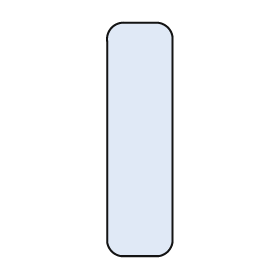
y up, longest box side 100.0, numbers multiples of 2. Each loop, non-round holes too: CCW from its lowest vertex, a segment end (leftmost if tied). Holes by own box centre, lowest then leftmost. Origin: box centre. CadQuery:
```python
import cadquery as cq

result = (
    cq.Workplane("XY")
    .moveTo(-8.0, -50.0)
    .lineTo(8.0, -50.0)
    .threePointArc((12.0, -48.0), (14.0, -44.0))
    .lineTo(14.0, 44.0)
    .threePointArc((12.0, 48.0), (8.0, 50.0))
    .lineTo(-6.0, 50.0)
    .threePointArc((-12.0, 48.0), (-14.0, 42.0))
    .lineTo(-14.0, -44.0)
    .threePointArc((-12.0, -48.0), (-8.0, -50.0))
    .close()
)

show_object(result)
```